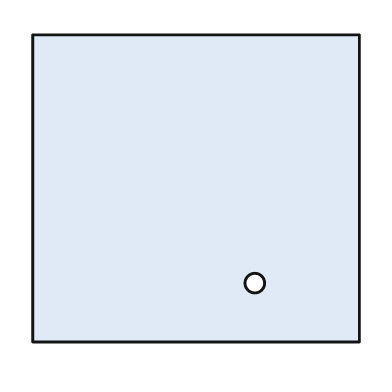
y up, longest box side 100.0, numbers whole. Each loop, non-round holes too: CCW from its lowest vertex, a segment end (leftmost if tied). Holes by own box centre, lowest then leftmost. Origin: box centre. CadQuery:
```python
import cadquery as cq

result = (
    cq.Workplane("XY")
    .moveTo(-50.0, -47.0)
    .lineTo(50.0, -47.0)
    .lineTo(50.0, 47.0)
    .lineTo(-50.0, 47.0)
    .close()
    .moveTo(18.0, -29.0)
    .circle(3.0)
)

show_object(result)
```